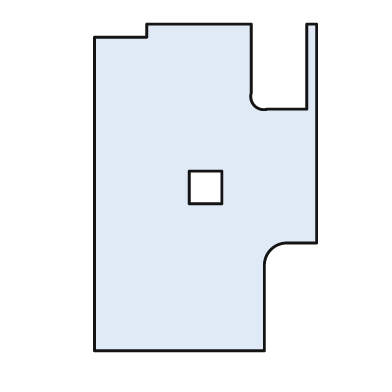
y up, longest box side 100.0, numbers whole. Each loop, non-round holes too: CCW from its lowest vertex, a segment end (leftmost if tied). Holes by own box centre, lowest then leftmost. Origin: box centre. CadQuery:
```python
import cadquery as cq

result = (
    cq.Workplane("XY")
    .moveTo(-34.0, -50.0)
    .lineTo(18.0, -50.0)
    .lineTo(18.0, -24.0)
    .threePointArc((20.0, -19.0), (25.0, -17.0))
    .lineTo(34.0, -17.0)
    .lineTo(34.0, 50.0)
    .lineTo(31.0, 50.0)
    .lineTo(31.0, 24.0)
    .lineTo(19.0, 24.0)
    .threePointArc((15.0, 25.0), (14.0, 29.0))
    .lineTo(14.0, 50.0)
    .lineTo(-18.0, 50.0)
    .lineTo(-18.0, 46.0)
    .lineTo(-34.0, 46.0)
    .close()
    .moveTo(-5.0, -5.0)
    .lineTo(5.0, -5.0)
    .lineTo(5.0, 5.0)
    .lineTo(-5.0, 5.0)
    .close()
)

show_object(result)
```